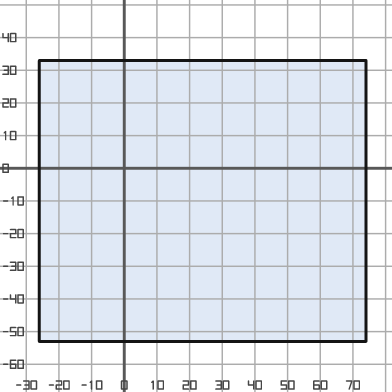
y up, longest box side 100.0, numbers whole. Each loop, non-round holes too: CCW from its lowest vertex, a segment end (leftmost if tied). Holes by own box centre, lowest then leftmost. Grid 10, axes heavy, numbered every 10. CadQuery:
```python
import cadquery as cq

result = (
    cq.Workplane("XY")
    .moveTo(-26.0, -53.0)
    .lineTo(74.0, -53.0)
    .lineTo(74.0, 33.0)
    .lineTo(-26.0, 33.0)
    .close()
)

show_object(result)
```